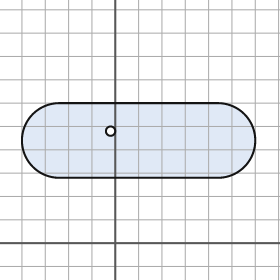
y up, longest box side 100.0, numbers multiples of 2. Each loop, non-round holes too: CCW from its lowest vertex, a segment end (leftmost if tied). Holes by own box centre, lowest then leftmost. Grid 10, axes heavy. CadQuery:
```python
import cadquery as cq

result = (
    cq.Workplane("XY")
    .moveTo(-24.0, 28.0)
    .lineTo(44.0, 28.0)
    .threePointArc((60.0, 44.0), (44.0, 60.0))
    .lineTo(-24.0, 60.0)
    .threePointArc((-40.0, 44.0), (-24.0, 28.0))
    .close()
    .moveTo(-2.0, 48.0)
    .circle(2.0)
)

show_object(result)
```